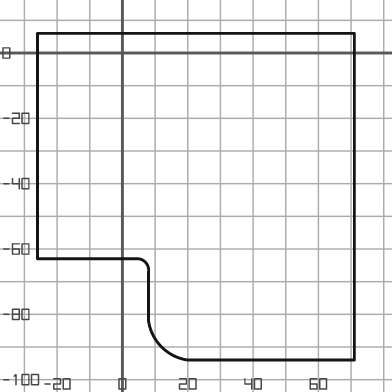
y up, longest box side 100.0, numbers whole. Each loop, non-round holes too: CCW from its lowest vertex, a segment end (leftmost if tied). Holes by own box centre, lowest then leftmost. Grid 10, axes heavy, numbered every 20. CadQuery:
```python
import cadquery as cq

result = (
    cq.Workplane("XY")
    .moveTo(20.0, -94.0)
    .lineTo(71.0, -94.0)
    .lineTo(71.0, 6.0)
    .lineTo(-26.0, 6.0)
    .lineTo(-26.0, -63.0)
    .lineTo(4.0, -63.0)
    .threePointArc((7.0, -64.0), (8.0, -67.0))
    .lineTo(8.0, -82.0)
    .threePointArc((12.0, -90.0), (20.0, -94.0))
    .close()
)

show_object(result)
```